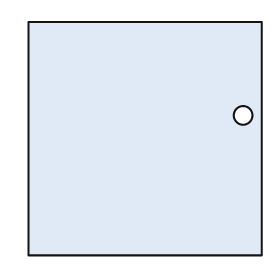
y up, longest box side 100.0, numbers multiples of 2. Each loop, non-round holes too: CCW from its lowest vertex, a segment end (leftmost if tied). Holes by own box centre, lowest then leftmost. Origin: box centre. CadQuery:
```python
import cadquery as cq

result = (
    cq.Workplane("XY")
    .moveTo(-50.0, -50.0)
    .lineTo(50.0, -50.0)
    .lineTo(50.0, 50.0)
    .lineTo(-50.0, 50.0)
    .close()
    .moveTo(42.0, 10.0)
    .circle(4.0)
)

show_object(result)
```